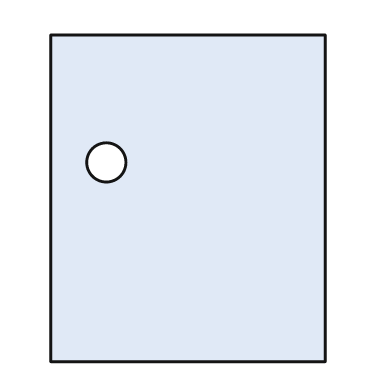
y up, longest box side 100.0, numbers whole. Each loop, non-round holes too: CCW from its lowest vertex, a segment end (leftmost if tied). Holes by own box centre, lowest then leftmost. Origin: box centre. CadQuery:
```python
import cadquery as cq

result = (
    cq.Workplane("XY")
    .moveTo(-42.0, -50.0)
    .lineTo(42.0, -50.0)
    .lineTo(42.0, 50.0)
    .lineTo(-42.0, 50.0)
    .close()
    .moveTo(-25.0, 11.0)
    .circle(6.0)
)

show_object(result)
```